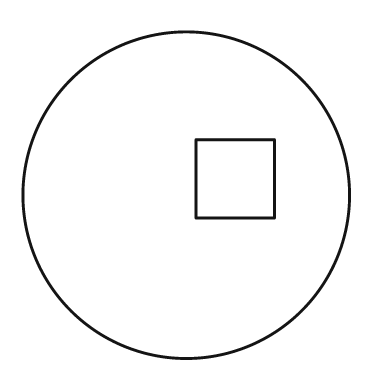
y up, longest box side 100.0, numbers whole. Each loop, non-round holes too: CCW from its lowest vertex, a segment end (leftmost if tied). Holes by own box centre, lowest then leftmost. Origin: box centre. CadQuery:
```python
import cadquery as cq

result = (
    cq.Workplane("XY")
    .moveTo(0.0, 0.0)
    .circle(50.0)
    .moveTo(3.0, -7.0)
    .lineTo(27.0, -7.0)
    .lineTo(27.0, 17.0)
    .lineTo(3.0, 17.0)
    .close()
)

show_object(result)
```